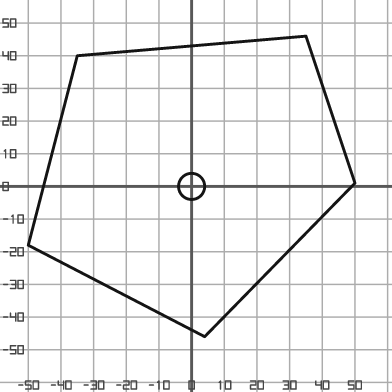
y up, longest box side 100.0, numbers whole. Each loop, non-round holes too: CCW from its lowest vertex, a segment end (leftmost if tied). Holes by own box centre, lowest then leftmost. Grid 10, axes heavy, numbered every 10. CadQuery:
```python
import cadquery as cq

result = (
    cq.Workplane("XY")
    .moveTo(4.0, -46.0)
    .lineTo(50.0, 1.0)
    .lineTo(35.0, 46.0)
    .lineTo(-35.0, 40.0)
    .lineTo(-50.0, -18.0)
    .close()
    .moveTo(0.0, 0.0)
    .circle(4.0)
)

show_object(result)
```